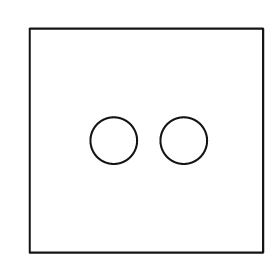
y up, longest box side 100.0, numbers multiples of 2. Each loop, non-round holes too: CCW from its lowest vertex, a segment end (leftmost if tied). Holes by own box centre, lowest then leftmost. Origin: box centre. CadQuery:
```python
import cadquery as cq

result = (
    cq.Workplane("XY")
    .moveTo(-50.0, -48.0)
    .lineTo(50.0, -48.0)
    .lineTo(50.0, 48.0)
    .lineTo(-50.0, 48.0)
    .close()
    .moveTo(-14.0, 0.0)
    .circle(10.0)
    .moveTo(16.0, 0.0)
    .circle(10.0)
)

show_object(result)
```